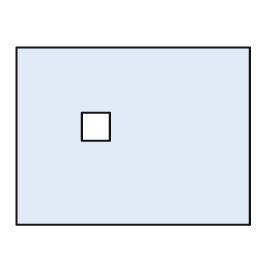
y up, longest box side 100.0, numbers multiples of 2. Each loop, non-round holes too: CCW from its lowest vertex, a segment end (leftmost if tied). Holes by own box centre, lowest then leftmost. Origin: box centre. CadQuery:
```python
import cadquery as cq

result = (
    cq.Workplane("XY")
    .moveTo(-50.0, -38.0)
    .lineTo(50.0, -38.0)
    .lineTo(50.0, 38.0)
    .lineTo(-50.0, 38.0)
    .close()
    .moveTo(-22.0, -2.0)
    .lineTo(-10.0, -2.0)
    .lineTo(-10.0, 10.0)
    .lineTo(-22.0, 10.0)
    .close()
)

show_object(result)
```